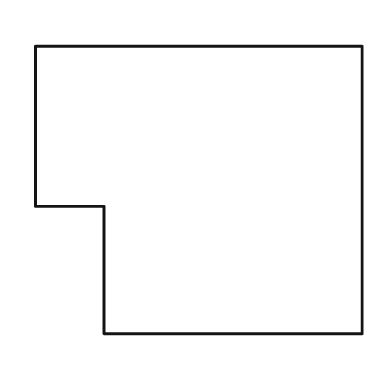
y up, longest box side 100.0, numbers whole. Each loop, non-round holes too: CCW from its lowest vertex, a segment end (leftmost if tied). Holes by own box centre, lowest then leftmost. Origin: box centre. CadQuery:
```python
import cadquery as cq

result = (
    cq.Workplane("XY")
    .moveTo(-29.0, -44.0)
    .lineTo(50.0, -44.0)
    .lineTo(50.0, 44.0)
    .lineTo(-50.0, 44.0)
    .lineTo(-50.0, -5.0)
    .lineTo(-29.0, -5.0)
    .close()
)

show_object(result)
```